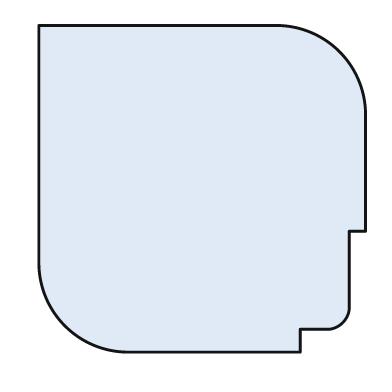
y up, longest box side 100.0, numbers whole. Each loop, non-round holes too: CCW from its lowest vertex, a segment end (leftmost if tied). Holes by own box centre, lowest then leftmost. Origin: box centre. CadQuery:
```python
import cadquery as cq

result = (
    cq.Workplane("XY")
    .moveTo(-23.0, -50.0)
    .lineTo(30.0, -50.0)
    .lineTo(30.0, -43.0)
    .lineTo(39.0, -43.0)
    .threePointArc((43.0, -41.0), (45.0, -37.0))
    .lineTo(45.0, -13.0)
    .lineTo(50.0, -13.0)
    .lineTo(50.0, 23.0)
    .threePointArc((42.0, 42.0), (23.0, 50.0))
    .lineTo(-50.0, 50.0)
    .lineTo(-50.0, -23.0)
    .threePointArc((-42.0, -42.0), (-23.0, -50.0))
    .close()
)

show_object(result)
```